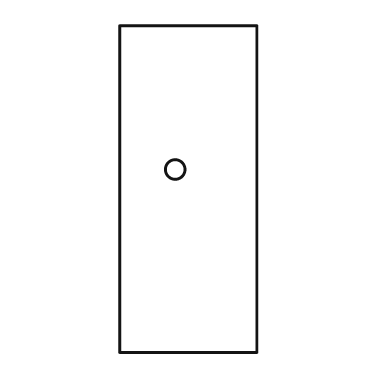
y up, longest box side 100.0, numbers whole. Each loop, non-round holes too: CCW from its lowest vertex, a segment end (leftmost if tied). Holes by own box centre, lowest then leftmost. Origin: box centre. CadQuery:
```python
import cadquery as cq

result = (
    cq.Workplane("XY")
    .moveTo(-21.0, -50.0)
    .lineTo(21.0, -50.0)
    .lineTo(21.0, 50.0)
    .lineTo(-21.0, 50.0)
    .close()
    .moveTo(-4.0, 6.0)
    .circle(3.0)
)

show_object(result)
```